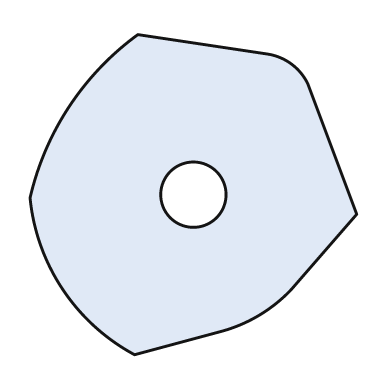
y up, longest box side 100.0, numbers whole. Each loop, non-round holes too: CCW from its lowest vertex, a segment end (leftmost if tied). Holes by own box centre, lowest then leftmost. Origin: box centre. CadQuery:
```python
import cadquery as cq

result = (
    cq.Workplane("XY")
    .moveTo(-18.0, -49.0)
    .lineTo(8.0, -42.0)
    .threePointArc((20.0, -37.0), (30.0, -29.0))
    .lineTo(50.0, -6.0)
    .lineTo(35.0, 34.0)
    .threePointArc((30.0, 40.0), (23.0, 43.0))
    .lineTo(-17.0, 49.0)
    .threePointArc((-38.0, 27.0), (-50.0, -1.0))
    .threePointArc((-40.0, -29.0), (-18.0, -49.0))
    .close()
    .moveTo(0.0, 0.0)
    .circle(10.0)
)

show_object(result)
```